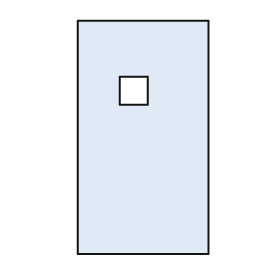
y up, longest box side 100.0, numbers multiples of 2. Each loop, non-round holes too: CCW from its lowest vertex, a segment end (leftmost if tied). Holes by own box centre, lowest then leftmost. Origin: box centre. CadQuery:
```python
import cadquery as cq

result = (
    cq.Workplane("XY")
    .moveTo(-28.0, -50.0)
    .lineTo(28.0, -50.0)
    .lineTo(28.0, 50.0)
    .lineTo(-28.0, 50.0)
    .close()
    .moveTo(-10.0, 14.0)
    .lineTo(2.0, 14.0)
    .lineTo(2.0, 26.0)
    .lineTo(-10.0, 26.0)
    .close()
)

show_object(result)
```